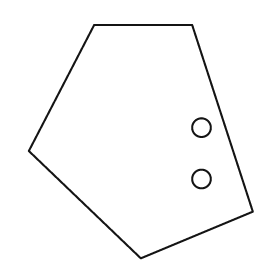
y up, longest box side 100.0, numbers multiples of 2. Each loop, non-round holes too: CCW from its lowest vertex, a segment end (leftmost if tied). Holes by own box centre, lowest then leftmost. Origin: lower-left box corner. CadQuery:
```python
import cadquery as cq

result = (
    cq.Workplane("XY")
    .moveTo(48.0, 0.0)
    .lineTo(96.0, 20.0)
    .lineTo(70.0, 100.0)
    .lineTo(28.0, 100.0)
    .lineTo(0.0, 46.0)
    .close()
    .moveTo(74.0, 34.0)
    .circle(4.0)
    .moveTo(74.0, 56.0)
    .circle(4.0)
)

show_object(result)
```